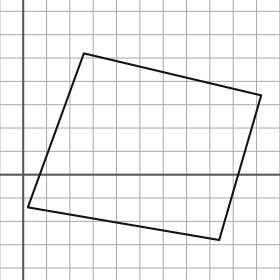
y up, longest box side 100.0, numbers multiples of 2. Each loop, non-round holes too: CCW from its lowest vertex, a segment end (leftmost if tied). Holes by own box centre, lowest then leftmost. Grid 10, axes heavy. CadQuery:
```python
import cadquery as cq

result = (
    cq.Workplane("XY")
    .moveTo(84.0, -28.0)
    .lineTo(102.0, 34.0)
    .lineTo(26.0, 52.0)
    .lineTo(2.0, -14.0)
    .close()
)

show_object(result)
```